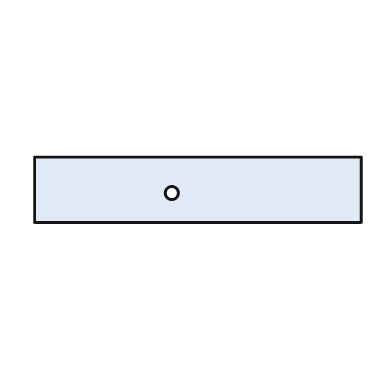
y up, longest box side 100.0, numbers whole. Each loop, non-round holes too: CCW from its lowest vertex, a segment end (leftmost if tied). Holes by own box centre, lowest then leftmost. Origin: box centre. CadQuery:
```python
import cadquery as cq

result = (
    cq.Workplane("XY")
    .moveTo(-50.0, -10.0)
    .lineTo(50.0, -10.0)
    .lineTo(50.0, 10.0)
    .lineTo(-50.0, 10.0)
    .close()
    .moveTo(-8.0, -1.0)
    .circle(2.0)
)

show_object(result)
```